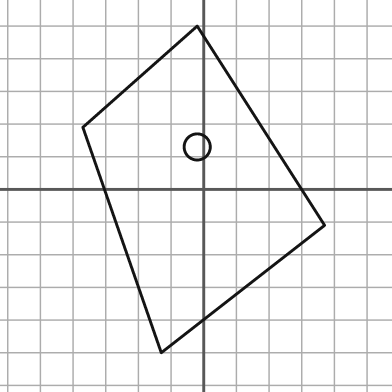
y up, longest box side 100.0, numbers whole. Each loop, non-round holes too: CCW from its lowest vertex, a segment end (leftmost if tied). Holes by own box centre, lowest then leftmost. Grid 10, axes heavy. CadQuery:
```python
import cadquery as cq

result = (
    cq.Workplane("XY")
    .moveTo(-13.0, -50.0)
    .lineTo(37.0, -11.0)
    .lineTo(-2.0, 50.0)
    .lineTo(-37.0, 19.0)
    .close()
    .moveTo(-2.0, 13.0)
    .circle(4.0)
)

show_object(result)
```